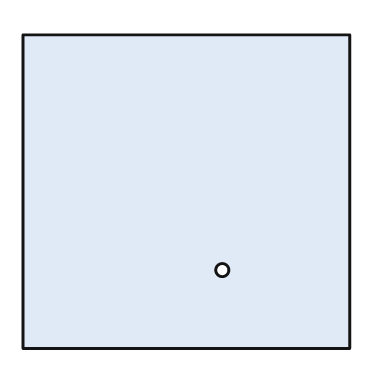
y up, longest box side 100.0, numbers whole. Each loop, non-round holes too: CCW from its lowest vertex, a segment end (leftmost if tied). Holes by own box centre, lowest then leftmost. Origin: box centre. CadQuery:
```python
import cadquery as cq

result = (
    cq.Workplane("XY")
    .moveTo(-50.0, -48.0)
    .lineTo(50.0, -48.0)
    .lineTo(50.0, 48.0)
    .lineTo(-50.0, 48.0)
    .close()
    .moveTo(11.0, -24.0)
    .circle(2.0)
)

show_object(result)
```